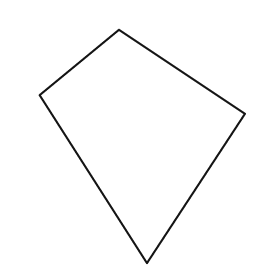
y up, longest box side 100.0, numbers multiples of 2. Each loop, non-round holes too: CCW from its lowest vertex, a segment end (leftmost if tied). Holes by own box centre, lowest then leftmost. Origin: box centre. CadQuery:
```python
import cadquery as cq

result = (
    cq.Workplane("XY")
    .moveTo(2.0, -50.0)
    .lineTo(44.0, 14.0)
    .lineTo(-10.0, 50.0)
    .lineTo(-44.0, 22.0)
    .close()
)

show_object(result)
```